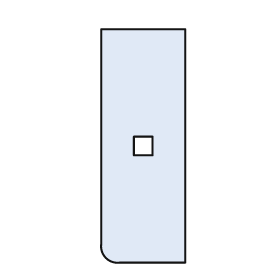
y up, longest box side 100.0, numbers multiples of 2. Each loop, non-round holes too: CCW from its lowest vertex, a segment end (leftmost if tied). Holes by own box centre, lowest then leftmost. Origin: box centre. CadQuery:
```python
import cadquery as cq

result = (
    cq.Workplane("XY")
    .moveTo(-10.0, -50.0)
    .lineTo(18.0, -50.0)
    .lineTo(18.0, 50.0)
    .lineTo(-18.0, 50.0)
    .lineTo(-18.0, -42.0)
    .threePointArc((-16.0, -48.0), (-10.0, -50.0))
    .close()
    .moveTo(-4.0, -4.0)
    .lineTo(4.0, -4.0)
    .lineTo(4.0, 4.0)
    .lineTo(-4.0, 4.0)
    .close()
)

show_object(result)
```